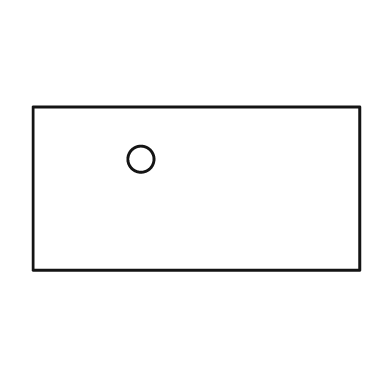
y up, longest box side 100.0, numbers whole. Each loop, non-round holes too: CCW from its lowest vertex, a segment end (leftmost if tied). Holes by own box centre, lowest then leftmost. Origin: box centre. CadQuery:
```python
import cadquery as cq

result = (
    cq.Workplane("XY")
    .moveTo(-50.0, -25.0)
    .lineTo(50.0, -25.0)
    .lineTo(50.0, 25.0)
    .lineTo(-50.0, 25.0)
    .close()
    .moveTo(-17.0, 9.0)
    .circle(4.0)
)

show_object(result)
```